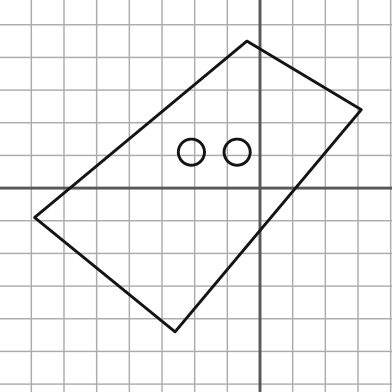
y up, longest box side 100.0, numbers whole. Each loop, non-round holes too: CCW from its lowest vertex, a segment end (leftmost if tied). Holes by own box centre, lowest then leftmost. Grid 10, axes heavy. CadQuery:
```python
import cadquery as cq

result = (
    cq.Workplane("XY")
    .moveTo(-26.0, -44.0)
    .lineTo(31.0, 24.0)
    .lineTo(-4.0, 45.0)
    .lineTo(-69.0, -9.0)
    .close()
    .moveTo(-21.0, 11.0)
    .circle(4.0)
    .moveTo(-7.0, 11.0)
    .circle(4.0)
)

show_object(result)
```